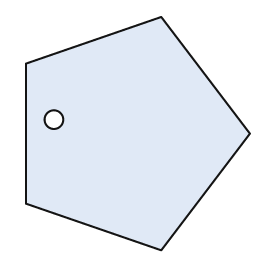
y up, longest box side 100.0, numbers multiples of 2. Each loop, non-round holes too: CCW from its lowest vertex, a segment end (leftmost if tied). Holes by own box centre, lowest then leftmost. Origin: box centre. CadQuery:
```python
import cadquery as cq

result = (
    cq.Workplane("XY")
    .moveTo(10.0, -50.0)
    .lineTo(48.0, 0.0)
    .lineTo(10.0, 50.0)
    .lineTo(-48.0, 30.0)
    .lineTo(-48.0, -30.0)
    .close()
    .moveTo(-36.0, 6.0)
    .circle(4.0)
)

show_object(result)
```